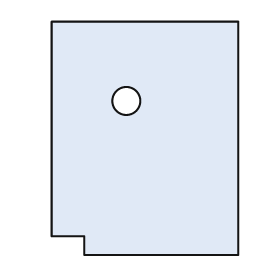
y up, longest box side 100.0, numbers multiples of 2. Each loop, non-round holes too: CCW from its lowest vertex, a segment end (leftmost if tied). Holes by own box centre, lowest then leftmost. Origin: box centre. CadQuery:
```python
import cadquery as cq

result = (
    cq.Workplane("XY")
    .moveTo(-26.0, -50.0)
    .lineTo(40.0, -50.0)
    .lineTo(40.0, 50.0)
    .lineTo(-40.0, 50.0)
    .lineTo(-40.0, -42.0)
    .lineTo(-26.0, -42.0)
    .close()
    .moveTo(-8.0, 16.0)
    .circle(6.0)
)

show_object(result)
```